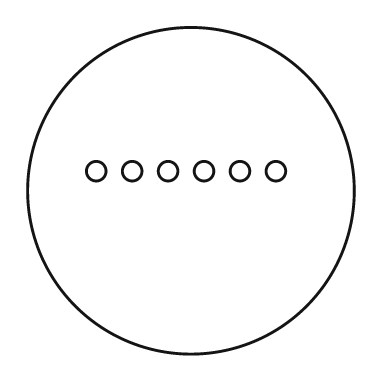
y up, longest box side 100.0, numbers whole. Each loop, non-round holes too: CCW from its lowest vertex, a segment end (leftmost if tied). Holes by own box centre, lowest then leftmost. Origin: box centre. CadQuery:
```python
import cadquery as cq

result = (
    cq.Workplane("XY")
    .moveTo(0.0, 0.0)
    .circle(50.0)
    .moveTo(-29.0, 6.0)
    .circle(3.0)
    .moveTo(-18.0, 6.0)
    .circle(3.0)
    .moveTo(-7.0, 6.0)
    .circle(3.0)
    .moveTo(4.0, 6.0)
    .circle(3.0)
    .moveTo(15.0, 6.0)
    .circle(3.0)
    .moveTo(26.0, 6.0)
    .circle(3.0)
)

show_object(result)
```